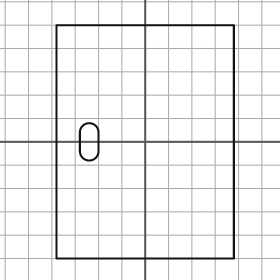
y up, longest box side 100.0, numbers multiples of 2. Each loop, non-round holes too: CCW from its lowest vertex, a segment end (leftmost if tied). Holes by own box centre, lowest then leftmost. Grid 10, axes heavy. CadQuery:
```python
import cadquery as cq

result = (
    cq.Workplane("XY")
    .moveTo(-38.0, -50.0)
    .lineTo(38.0, -50.0)
    .lineTo(38.0, 50.0)
    .lineTo(-38.0, 50.0)
    .close()
    .moveTo(-28.0, -4.0)
    .threePointArc((-24.0, -8.0), (-20.0, -4.0))
    .lineTo(-20.0, 4.0)
    .threePointArc((-24.0, 8.0), (-28.0, 4.0))
    .close()
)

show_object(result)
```